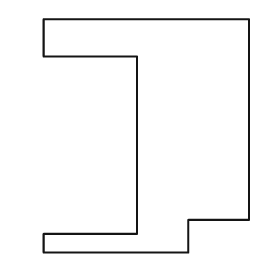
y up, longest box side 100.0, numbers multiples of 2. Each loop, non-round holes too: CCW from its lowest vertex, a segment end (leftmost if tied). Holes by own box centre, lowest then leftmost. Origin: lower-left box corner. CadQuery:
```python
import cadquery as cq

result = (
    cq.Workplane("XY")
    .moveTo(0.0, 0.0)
    .lineTo(62.0, 0.0)
    .lineTo(62.0, 14.0)
    .lineTo(88.0, 14.0)
    .lineTo(88.0, 100.0)
    .lineTo(0.0, 100.0)
    .lineTo(0.0, 84.0)
    .lineTo(40.0, 84.0)
    .lineTo(40.0, 8.0)
    .lineTo(0.0, 8.0)
    .close()
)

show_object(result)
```